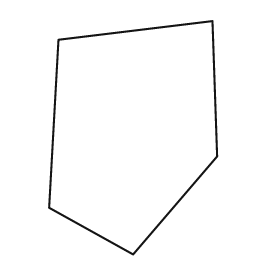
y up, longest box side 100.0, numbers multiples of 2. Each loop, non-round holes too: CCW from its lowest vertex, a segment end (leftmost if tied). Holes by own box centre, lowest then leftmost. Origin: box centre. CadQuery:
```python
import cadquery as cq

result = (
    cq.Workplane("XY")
    .moveTo(0.0, -50.0)
    .lineTo(36.0, -8.0)
    .lineTo(34.0, 50.0)
    .lineTo(-32.0, 42.0)
    .lineTo(-36.0, -30.0)
    .close()
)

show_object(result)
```